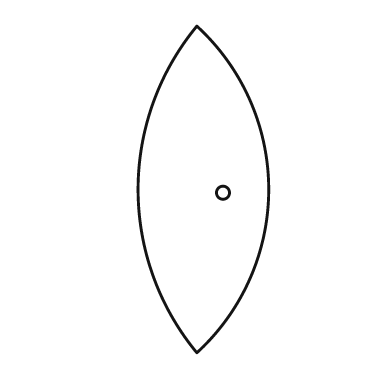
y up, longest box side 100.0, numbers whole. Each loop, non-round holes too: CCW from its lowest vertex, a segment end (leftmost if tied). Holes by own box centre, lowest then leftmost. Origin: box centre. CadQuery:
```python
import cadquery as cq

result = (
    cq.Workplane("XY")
    .moveTo(-2.0, -50.0)
    .threePointArc((20.0, 0.0), (-2.0, 50.0))
    .threePointArc((-20.0, 0.0), (-2.0, -50.0))
    .close()
    .moveTo(6.0, -1.0)
    .circle(2.0)
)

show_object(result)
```